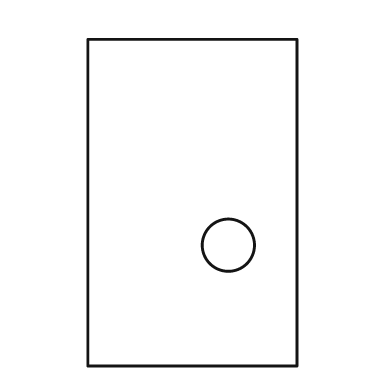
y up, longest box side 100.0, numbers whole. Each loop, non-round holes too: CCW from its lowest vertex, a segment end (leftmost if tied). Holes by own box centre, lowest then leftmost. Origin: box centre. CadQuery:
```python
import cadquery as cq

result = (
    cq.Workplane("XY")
    .moveTo(-32.0, -50.0)
    .lineTo(32.0, -50.0)
    .lineTo(32.0, 50.0)
    .lineTo(-32.0, 50.0)
    .close()
    .moveTo(11.0, -13.0)
    .circle(8.0)
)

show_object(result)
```